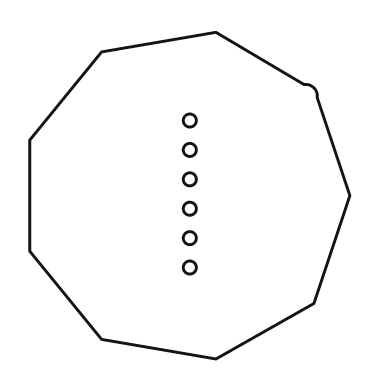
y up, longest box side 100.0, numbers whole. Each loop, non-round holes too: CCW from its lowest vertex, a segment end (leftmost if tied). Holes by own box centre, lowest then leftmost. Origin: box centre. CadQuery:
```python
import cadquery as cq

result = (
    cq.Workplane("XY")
    .moveTo(8.0, -50.0)
    .lineTo(38.0, -33.0)
    .lineTo(49.0, 0.0)
    .lineTo(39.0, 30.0)
    .threePointArc((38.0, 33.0), (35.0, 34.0))
    .lineTo(8.0, 50.0)
    .lineTo(-27.0, 44.0)
    .lineTo(-49.0, 17.0)
    .lineTo(-49.0, -17.0)
    .lineTo(-27.0, -44.0)
    .close()
    .moveTo(0.0, -22.0)
    .circle(2.0)
    .moveTo(0.0, -13.0)
    .circle(2.0)
    .moveTo(0.0, -4.0)
    .circle(2.0)
    .moveTo(0.0, 5.0)
    .circle(2.0)
    .moveTo(0.0, 14.0)
    .circle(2.0)
    .moveTo(0.0, 23.0)
    .circle(2.0)
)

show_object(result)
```